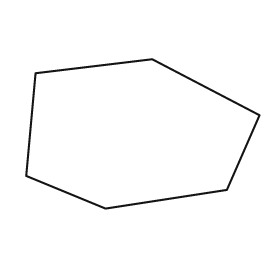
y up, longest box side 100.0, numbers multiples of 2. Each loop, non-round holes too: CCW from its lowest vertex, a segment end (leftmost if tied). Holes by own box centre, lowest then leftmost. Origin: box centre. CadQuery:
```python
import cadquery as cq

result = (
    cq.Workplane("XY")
    .moveTo(-16.0, -32.0)
    .lineTo(36.0, -24.0)
    .lineTo(50.0, 8.0)
    .lineTo(4.0, 32.0)
    .lineTo(-46.0, 26.0)
    .lineTo(-50.0, -18.0)
    .close()
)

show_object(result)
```